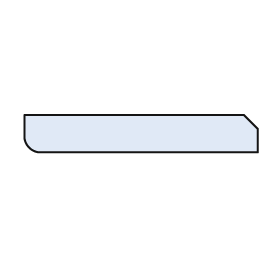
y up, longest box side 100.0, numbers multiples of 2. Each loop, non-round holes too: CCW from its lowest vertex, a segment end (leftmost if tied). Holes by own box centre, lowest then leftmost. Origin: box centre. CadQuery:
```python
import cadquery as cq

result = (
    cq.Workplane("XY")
    .moveTo(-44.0, -8.0)
    .lineTo(50.0, -8.0)
    .lineTo(50.0, 2.0)
    .lineTo(44.0, 8.0)
    .lineTo(-50.0, 8.0)
    .lineTo(-50.0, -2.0)
    .threePointArc((-48.0, -6.0), (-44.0, -8.0))
    .close()
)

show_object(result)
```